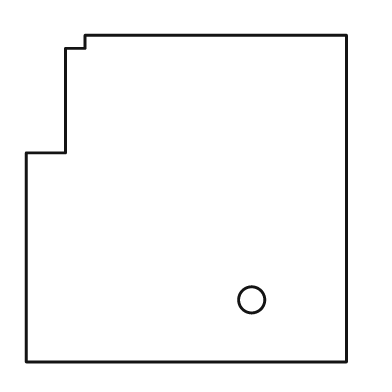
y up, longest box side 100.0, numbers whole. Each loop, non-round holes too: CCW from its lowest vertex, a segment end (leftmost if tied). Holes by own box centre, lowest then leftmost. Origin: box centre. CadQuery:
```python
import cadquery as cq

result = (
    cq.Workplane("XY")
    .moveTo(-49.0, -50.0)
    .lineTo(49.0, -50.0)
    .lineTo(49.0, 50.0)
    .lineTo(-31.0, 50.0)
    .lineTo(-31.0, 46.0)
    .lineTo(-37.0, 46.0)
    .lineTo(-37.0, 14.0)
    .lineTo(-49.0, 14.0)
    .close()
    .moveTo(20.0, -31.0)
    .circle(4.0)
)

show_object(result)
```